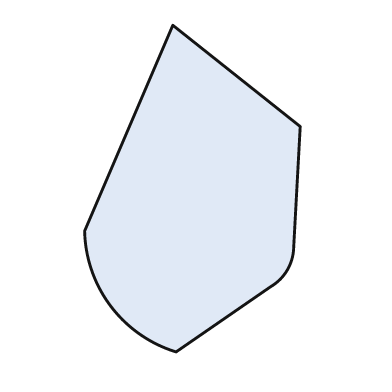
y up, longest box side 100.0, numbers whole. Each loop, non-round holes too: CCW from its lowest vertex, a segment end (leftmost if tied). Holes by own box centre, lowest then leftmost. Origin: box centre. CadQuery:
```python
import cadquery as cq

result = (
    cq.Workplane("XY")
    .moveTo(-5.0, -50.0)
    .lineTo(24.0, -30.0)
    .threePointArc((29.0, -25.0), (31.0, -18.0))
    .lineTo(33.0, 19.0)
    .lineTo(-6.0, 50.0)
    .lineTo(-33.0, -13.0)
    .threePointArc((-25.0, -36.0), (-5.0, -50.0))
    .close()
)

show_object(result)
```